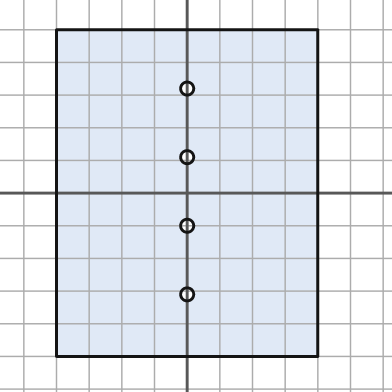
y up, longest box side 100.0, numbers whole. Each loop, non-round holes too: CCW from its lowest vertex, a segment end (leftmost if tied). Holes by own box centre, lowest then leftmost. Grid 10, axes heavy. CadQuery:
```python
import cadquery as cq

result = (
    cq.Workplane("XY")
    .moveTo(-40.0, -50.0)
    .lineTo(40.0, -50.0)
    .lineTo(40.0, 50.0)
    .lineTo(-40.0, 50.0)
    .close()
    .moveTo(0.0, -31.0)
    .circle(2.0)
    .moveTo(0.0, -10.0)
    .circle(2.0)
    .moveTo(0.0, 11.0)
    .circle(2.0)
    .moveTo(0.0, 32.0)
    .circle(2.0)
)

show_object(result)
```